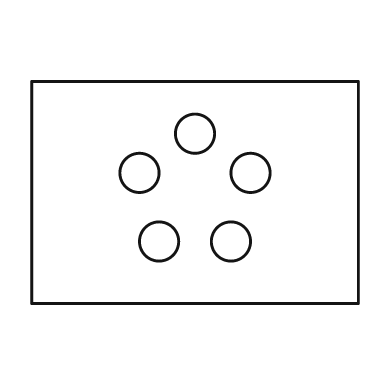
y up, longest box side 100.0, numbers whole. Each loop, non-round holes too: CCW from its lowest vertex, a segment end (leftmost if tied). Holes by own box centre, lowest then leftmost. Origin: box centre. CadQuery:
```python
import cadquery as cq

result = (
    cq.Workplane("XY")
    .moveTo(-50.0, -34.0)
    .lineTo(50.0, -34.0)
    .lineTo(50.0, 34.0)
    .lineTo(-50.0, 34.0)
    .close()
    .moveTo(-11.0, -15.0)
    .circle(6.0)
    .moveTo(11.0, -15.0)
    .circle(6.0)
    .moveTo(-17.0, 6.0)
    .circle(6.0)
    .moveTo(17.0, 6.0)
    .circle(6.0)
    .moveTo(0.0, 18.0)
    .circle(6.0)
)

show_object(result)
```